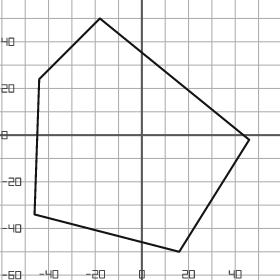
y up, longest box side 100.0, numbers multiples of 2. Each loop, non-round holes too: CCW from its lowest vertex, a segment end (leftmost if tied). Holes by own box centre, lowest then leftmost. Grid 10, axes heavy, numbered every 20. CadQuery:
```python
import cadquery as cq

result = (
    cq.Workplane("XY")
    .moveTo(16.0, -50.0)
    .lineTo(46.0, -2.0)
    .lineTo(-18.0, 50.0)
    .lineTo(-44.0, 24.0)
    .lineTo(-46.0, -34.0)
    .close()
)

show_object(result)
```